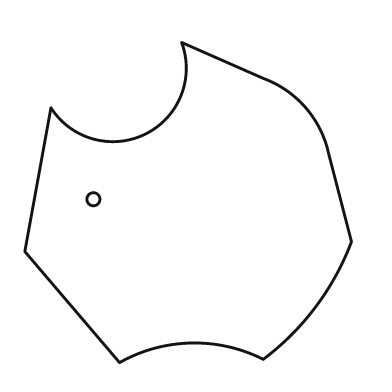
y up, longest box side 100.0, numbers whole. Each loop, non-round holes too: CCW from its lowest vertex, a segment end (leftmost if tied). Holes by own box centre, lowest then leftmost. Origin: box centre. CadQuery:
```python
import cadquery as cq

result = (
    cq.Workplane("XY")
    .moveTo(-21.0, -49.0)
    .threePointArc((1.0, -43.0), (23.0, -48.0))
    .threePointArc((39.0, -32.0), (50.0, -12.0))
    .lineTo(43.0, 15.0)
    .threePointArc((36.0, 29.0), (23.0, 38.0))
    .lineTo(-2.0, 49.0)
    .threePointArc((-13.0, 21.0), (-42.0, 29.0))
    .lineTo(-50.0, -15.0)
    .close()
    .moveTo(-29.0, 1.0)
    .circle(2.0)
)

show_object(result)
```